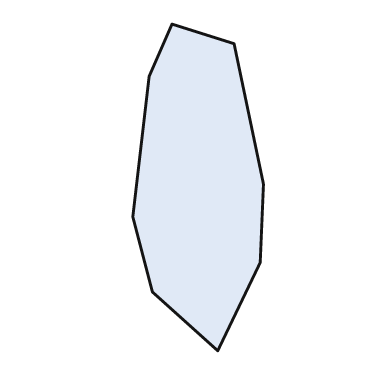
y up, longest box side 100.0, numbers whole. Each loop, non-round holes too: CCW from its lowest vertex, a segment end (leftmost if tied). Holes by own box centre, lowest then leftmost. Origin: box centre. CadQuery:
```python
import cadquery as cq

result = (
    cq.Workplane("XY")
    .moveTo(6.0, -50.0)
    .lineTo(19.0, -23.0)
    .lineTo(20.0, 1.0)
    .lineTo(11.0, 44.0)
    .lineTo(-8.0, 50.0)
    .lineTo(-15.0, 34.0)
    .lineTo(-20.0, -9.0)
    .lineTo(-14.0, -32.0)
    .close()
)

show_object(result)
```